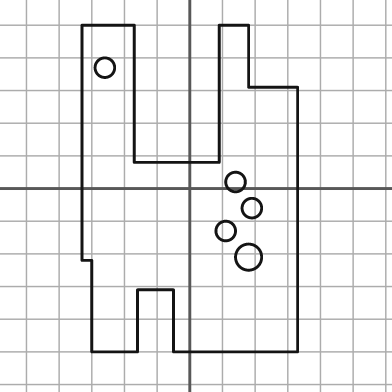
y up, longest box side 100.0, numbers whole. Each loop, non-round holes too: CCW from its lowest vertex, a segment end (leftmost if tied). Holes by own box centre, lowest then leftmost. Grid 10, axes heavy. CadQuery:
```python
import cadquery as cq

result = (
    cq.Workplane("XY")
    .moveTo(-30.0, -50.0)
    .lineTo(-16.0, -50.0)
    .lineTo(-16.0, -31.0)
    .lineTo(-5.0, -31.0)
    .lineTo(-5.0, -50.0)
    .lineTo(33.0, -50.0)
    .lineTo(33.0, 31.0)
    .lineTo(18.0, 31.0)
    .lineTo(18.0, 50.0)
    .lineTo(9.0, 50.0)
    .lineTo(9.0, 8.0)
    .lineTo(-17.0, 8.0)
    .lineTo(-17.0, 50.0)
    .lineTo(-33.0, 50.0)
    .lineTo(-33.0, -22.0)
    .lineTo(-30.0, -22.0)
    .close()
    .moveTo(18.0, -21.0)
    .circle(4.0)
    .moveTo(11.0, -13.0)
    .circle(3.0)
    .moveTo(19.0, -6.0)
    .circle(3.0)
    .moveTo(14.0, 2.0)
    .circle(3.0)
    .moveTo(-26.0, 37.0)
    .circle(3.0)
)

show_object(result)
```